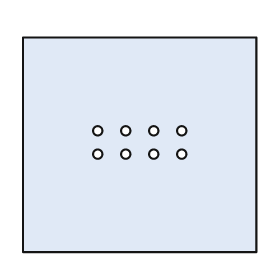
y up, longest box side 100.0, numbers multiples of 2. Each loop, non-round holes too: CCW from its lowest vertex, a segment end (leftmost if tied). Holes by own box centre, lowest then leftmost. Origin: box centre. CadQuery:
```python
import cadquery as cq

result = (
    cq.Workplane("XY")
    .moveTo(-50.0, -46.0)
    .lineTo(50.0, -46.0)
    .lineTo(50.0, 46.0)
    .lineTo(-50.0, 46.0)
    .close()
    .moveTo(-18.0, -4.0)
    .circle(2.0)
    .moveTo(-6.0, -4.0)
    .circle(2.0)
    .moveTo(6.0, -4.0)
    .circle(2.0)
    .moveTo(18.0, -4.0)
    .circle(2.0)
    .moveTo(-18.0, 6.0)
    .circle(2.0)
    .moveTo(-6.0, 6.0)
    .circle(2.0)
    .moveTo(6.0, 6.0)
    .circle(2.0)
    .moveTo(18.0, 6.0)
    .circle(2.0)
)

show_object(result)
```